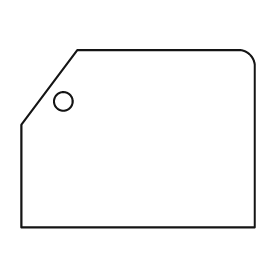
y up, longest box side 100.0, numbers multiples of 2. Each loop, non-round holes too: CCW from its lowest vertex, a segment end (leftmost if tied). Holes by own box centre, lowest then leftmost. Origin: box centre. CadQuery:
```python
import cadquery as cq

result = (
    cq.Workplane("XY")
    .moveTo(-50.0, -38.0)
    .lineTo(50.0, -38.0)
    .lineTo(50.0, 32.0)
    .threePointArc((48.0, 36.0), (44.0, 38.0))
    .lineTo(-26.0, 38.0)
    .lineTo(-50.0, 6.0)
    .close()
    .moveTo(-32.0, 16.0)
    .circle(4.0)
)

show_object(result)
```